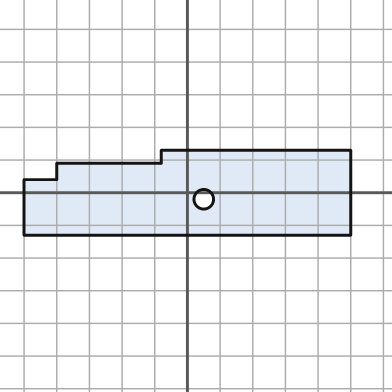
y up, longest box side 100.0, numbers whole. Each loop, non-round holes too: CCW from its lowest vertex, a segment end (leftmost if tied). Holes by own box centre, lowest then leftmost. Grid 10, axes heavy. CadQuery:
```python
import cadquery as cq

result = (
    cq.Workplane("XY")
    .moveTo(-50.0, -13.0)
    .lineTo(50.0, -13.0)
    .lineTo(50.0, 13.0)
    .lineTo(-8.0, 13.0)
    .lineTo(-8.0, 9.0)
    .lineTo(-40.0, 9.0)
    .lineTo(-40.0, 4.0)
    .lineTo(-50.0, 4.0)
    .close()
    .moveTo(5.0, -2.0)
    .circle(3.0)
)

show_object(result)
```